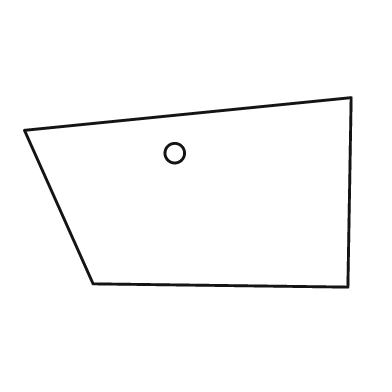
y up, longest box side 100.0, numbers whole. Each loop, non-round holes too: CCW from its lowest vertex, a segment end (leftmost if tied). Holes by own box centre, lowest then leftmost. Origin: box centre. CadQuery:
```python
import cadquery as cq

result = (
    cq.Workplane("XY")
    .moveTo(49.0, -29.0)
    .lineTo(50.0, 29.0)
    .lineTo(-50.0, 19.0)
    .lineTo(-29.0, -28.0)
    .close()
    .moveTo(-4.0, 12.0)
    .circle(3.0)
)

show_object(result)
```